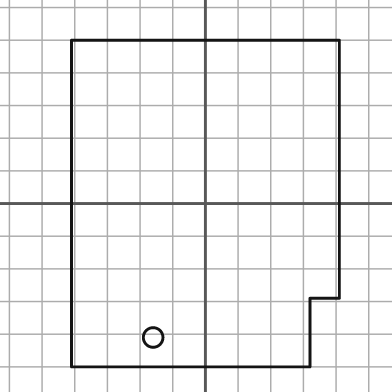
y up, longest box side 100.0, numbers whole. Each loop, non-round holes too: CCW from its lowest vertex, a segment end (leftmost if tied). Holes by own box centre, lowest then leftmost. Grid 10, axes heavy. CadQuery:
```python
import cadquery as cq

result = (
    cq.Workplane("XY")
    .moveTo(-41.0, -50.0)
    .lineTo(32.0, -50.0)
    .lineTo(32.0, -29.0)
    .lineTo(41.0, -29.0)
    .lineTo(41.0, 50.0)
    .lineTo(-41.0, 50.0)
    .close()
    .moveTo(-16.0, -41.0)
    .circle(3.0)
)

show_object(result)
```